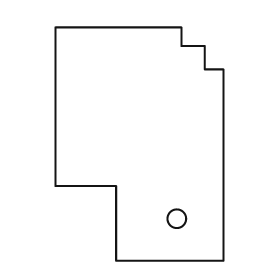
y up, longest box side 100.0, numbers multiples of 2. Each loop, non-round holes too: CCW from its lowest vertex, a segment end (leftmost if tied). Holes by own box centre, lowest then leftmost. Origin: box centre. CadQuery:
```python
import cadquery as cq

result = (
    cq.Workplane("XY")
    .moveTo(-10.0, -50.0)
    .lineTo(36.0, -50.0)
    .lineTo(36.0, 32.0)
    .lineTo(28.0, 32.0)
    .lineTo(28.0, 42.0)
    .lineTo(18.0, 42.0)
    .lineTo(18.0, 50.0)
    .lineTo(-36.0, 50.0)
    .lineTo(-36.0, -18.0)
    .lineTo(-10.0, -18.0)
    .close()
    .moveTo(16.0, -32.0)
    .circle(4.0)
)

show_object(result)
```